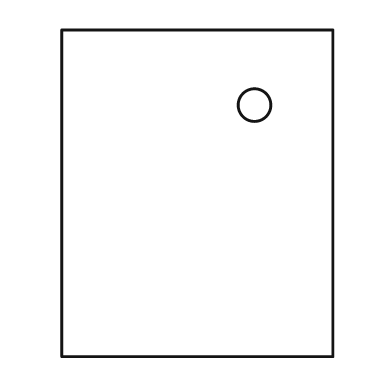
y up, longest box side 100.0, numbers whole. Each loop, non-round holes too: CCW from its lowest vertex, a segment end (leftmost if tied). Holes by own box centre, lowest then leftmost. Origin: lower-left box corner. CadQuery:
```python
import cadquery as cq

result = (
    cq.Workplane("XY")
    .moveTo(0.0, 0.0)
    .lineTo(83.0, 0.0)
    .lineTo(83.0, 100.0)
    .lineTo(0.0, 100.0)
    .close()
    .moveTo(59.0, 77.0)
    .circle(5.0)
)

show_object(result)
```